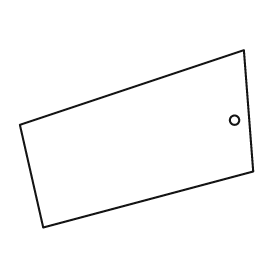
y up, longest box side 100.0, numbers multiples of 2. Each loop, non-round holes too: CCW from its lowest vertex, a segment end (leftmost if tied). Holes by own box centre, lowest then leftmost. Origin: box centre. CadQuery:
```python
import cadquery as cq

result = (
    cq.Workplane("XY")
    .moveTo(-40.0, -38.0)
    .lineTo(50.0, -14.0)
    .lineTo(46.0, 38.0)
    .lineTo(-50.0, 6.0)
    .close()
    .moveTo(42.0, 8.0)
    .circle(2.0)
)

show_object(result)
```